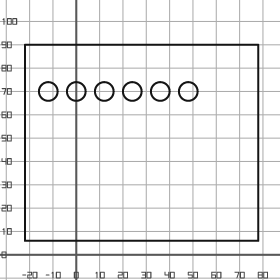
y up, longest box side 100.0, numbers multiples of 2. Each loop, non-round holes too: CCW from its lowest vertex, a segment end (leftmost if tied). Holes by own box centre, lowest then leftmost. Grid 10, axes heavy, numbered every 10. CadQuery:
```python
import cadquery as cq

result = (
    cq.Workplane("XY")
    .moveTo(-22.0, 6.0)
    .lineTo(78.0, 6.0)
    .lineTo(78.0, 90.0)
    .lineTo(-22.0, 90.0)
    .close()
    .moveTo(-12.0, 70.0)
    .circle(4.0)
    .moveTo(0.0, 70.0)
    .circle(4.0)
    .moveTo(12.0, 70.0)
    .circle(4.0)
    .moveTo(24.0, 70.0)
    .circle(4.0)
    .moveTo(36.0, 70.0)
    .circle(4.0)
    .moveTo(48.0, 70.0)
    .circle(4.0)
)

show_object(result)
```